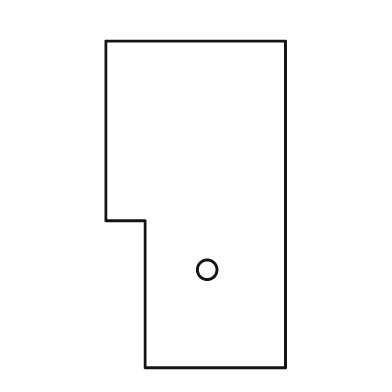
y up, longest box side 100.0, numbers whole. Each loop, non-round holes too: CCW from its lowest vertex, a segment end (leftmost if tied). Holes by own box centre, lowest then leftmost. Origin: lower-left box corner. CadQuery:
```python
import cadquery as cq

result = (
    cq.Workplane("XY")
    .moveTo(12.0, 0.0)
    .lineTo(55.0, 0.0)
    .lineTo(55.0, 100.0)
    .lineTo(0.0, 100.0)
    .lineTo(0.0, 45.0)
    .lineTo(12.0, 45.0)
    .close()
    .moveTo(31.0, 30.0)
    .circle(3.0)
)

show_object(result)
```